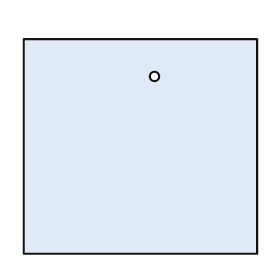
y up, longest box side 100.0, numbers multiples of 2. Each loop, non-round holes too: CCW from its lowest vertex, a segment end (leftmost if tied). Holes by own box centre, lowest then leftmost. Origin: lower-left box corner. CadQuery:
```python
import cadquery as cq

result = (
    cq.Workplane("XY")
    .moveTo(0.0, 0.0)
    .lineTo(100.0, 0.0)
    .lineTo(100.0, 92.0)
    .lineTo(0.0, 92.0)
    .close()
    .moveTo(56.0, 76.0)
    .circle(2.0)
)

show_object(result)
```